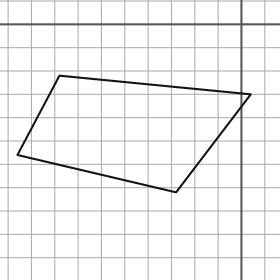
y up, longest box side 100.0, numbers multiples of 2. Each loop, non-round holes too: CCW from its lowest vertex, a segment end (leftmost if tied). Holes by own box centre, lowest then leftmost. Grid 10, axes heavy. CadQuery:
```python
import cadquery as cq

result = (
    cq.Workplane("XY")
    .moveTo(-28.0, -72.0)
    .lineTo(4.0, -30.0)
    .lineTo(-78.0, -22.0)
    .lineTo(-96.0, -56.0)
    .close()
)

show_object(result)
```